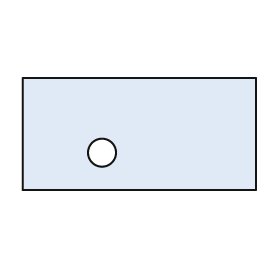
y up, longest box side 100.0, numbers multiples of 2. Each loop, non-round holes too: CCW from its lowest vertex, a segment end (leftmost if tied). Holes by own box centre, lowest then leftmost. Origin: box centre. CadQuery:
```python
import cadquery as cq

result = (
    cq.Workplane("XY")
    .moveTo(-50.0, -24.0)
    .lineTo(50.0, -24.0)
    .lineTo(50.0, 24.0)
    .lineTo(-50.0, 24.0)
    .close()
    .moveTo(-16.0, -8.0)
    .circle(6.0)
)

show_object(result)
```